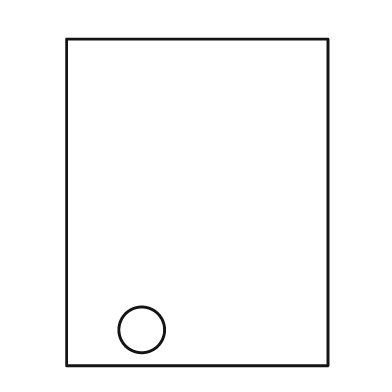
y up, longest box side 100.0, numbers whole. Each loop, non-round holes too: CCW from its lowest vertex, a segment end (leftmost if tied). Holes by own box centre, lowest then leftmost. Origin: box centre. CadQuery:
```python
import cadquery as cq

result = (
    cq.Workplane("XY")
    .moveTo(-40.0, -50.0)
    .lineTo(40.0, -50.0)
    .lineTo(40.0, 50.0)
    .lineTo(-40.0, 50.0)
    .close()
    .moveTo(-17.0, -39.0)
    .circle(7.0)
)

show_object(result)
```